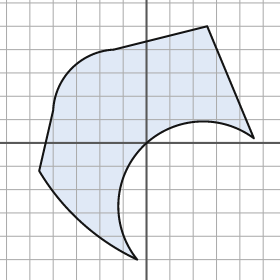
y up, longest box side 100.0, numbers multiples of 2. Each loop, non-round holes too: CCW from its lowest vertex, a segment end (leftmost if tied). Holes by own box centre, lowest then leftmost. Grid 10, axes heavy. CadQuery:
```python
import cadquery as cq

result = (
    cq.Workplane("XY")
    .moveTo(-4.0, -50.0)
    .threePointArc((-2.0, -2.0), (46.0, 2.0))
    .lineTo(26.0, 50.0)
    .lineTo(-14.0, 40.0)
    .threePointArc((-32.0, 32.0), (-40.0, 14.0))
    .lineTo(-46.0, -12.0)
    .threePointArc((-28.0, -34.0), (-4.0, -50.0))
    .close()
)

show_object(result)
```